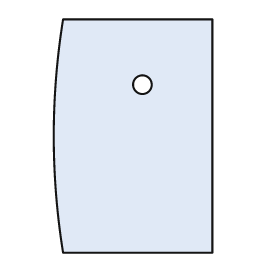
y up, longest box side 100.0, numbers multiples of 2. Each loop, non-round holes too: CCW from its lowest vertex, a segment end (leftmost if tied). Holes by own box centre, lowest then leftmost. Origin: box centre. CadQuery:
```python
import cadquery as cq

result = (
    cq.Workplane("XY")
    .moveTo(-30.0, -50.0)
    .lineTo(34.0, -50.0)
    .lineTo(34.0, 50.0)
    .lineTo(-30.0, 50.0)
    .threePointArc((-34.0, 0.0), (-30.0, -50.0))
    .close()
    .moveTo(4.0, 22.0)
    .circle(4.0)
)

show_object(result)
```